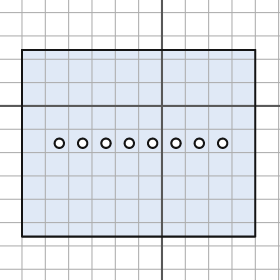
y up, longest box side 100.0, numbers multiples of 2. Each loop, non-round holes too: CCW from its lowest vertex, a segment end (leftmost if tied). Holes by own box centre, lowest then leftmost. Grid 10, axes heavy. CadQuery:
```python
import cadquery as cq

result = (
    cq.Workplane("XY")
    .moveTo(-60.0, -56.0)
    .lineTo(40.0, -56.0)
    .lineTo(40.0, 24.0)
    .lineTo(-60.0, 24.0)
    .close()
    .moveTo(-44.0, -16.0)
    .circle(2.0)
    .moveTo(-34.0, -16.0)
    .circle(2.0)
    .moveTo(-24.0, -16.0)
    .circle(2.0)
    .moveTo(-14.0, -16.0)
    .circle(2.0)
    .moveTo(-4.0, -16.0)
    .circle(2.0)
    .moveTo(6.0, -16.0)
    .circle(2.0)
    .moveTo(16.0, -16.0)
    .circle(2.0)
    .moveTo(26.0, -16.0)
    .circle(2.0)
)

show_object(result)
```